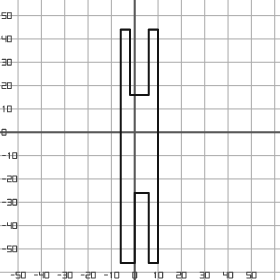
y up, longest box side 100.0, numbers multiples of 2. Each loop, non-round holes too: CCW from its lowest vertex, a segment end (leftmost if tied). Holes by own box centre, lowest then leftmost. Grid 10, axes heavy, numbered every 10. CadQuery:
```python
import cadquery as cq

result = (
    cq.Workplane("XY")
    .moveTo(-6.0, -56.0)
    .lineTo(0.0, -56.0)
    .lineTo(0.0, -26.0)
    .lineTo(6.0, -26.0)
    .lineTo(6.0, -56.0)
    .lineTo(10.0, -56.0)
    .lineTo(10.0, 44.0)
    .lineTo(6.0, 44.0)
    .lineTo(6.0, 16.0)
    .lineTo(-2.0, 16.0)
    .lineTo(-2.0, 44.0)
    .lineTo(-6.0, 44.0)
    .close()
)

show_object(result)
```